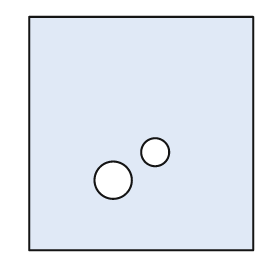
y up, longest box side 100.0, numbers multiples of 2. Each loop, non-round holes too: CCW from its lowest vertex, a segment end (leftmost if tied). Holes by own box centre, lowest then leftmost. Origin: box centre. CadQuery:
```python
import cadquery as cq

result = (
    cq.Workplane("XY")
    .moveTo(-48.0, -50.0)
    .lineTo(48.0, -50.0)
    .lineTo(48.0, 50.0)
    .lineTo(-48.0, 50.0)
    .close()
    .moveTo(-12.0, -20.0)
    .circle(8.0)
    .moveTo(6.0, -8.0)
    .circle(6.0)
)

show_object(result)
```